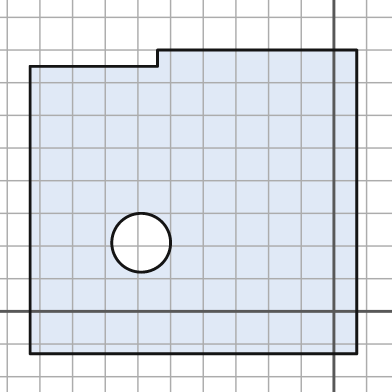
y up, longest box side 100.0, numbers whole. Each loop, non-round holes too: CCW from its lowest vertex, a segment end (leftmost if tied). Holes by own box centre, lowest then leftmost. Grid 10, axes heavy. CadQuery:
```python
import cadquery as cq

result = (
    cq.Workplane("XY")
    .moveTo(-93.0, -13.0)
    .lineTo(7.0, -13.0)
    .lineTo(7.0, 80.0)
    .lineTo(-54.0, 80.0)
    .lineTo(-54.0, 75.0)
    .lineTo(-93.0, 75.0)
    .close()
    .moveTo(-59.0, 21.0)
    .circle(9.0)
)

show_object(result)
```